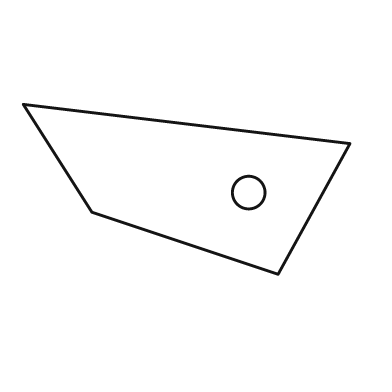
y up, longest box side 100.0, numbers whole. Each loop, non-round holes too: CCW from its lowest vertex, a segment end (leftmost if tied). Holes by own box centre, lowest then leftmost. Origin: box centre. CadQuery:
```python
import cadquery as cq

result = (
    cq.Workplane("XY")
    .moveTo(28.0, -26.0)
    .lineTo(50.0, 14.0)
    .lineTo(-50.0, 26.0)
    .lineTo(-29.0, -7.0)
    .close()
    .moveTo(19.0, -1.0)
    .circle(5.0)
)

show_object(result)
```